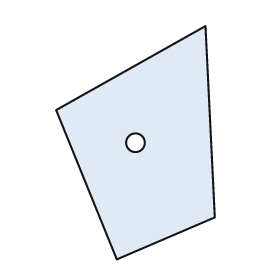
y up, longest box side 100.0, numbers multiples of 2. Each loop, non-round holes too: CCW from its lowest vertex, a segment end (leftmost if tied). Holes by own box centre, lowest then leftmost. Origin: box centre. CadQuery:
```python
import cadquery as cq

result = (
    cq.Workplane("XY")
    .moveTo(-8.0, -50.0)
    .lineTo(34.0, -32.0)
    .lineTo(30.0, 50.0)
    .lineTo(-34.0, 14.0)
    .close()
    .moveTo(0.0, 0.0)
    .circle(4.0)
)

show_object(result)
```